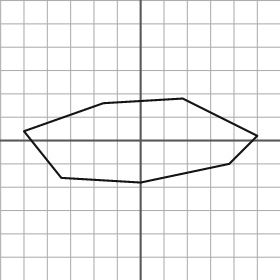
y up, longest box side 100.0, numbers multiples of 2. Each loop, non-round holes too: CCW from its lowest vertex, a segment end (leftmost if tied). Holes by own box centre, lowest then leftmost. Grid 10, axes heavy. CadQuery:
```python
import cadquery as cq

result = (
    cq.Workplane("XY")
    .moveTo(0.0, -18.0)
    .lineTo(38.0, -10.0)
    .lineTo(50.0, 2.0)
    .lineTo(18.0, 18.0)
    .lineTo(-16.0, 16.0)
    .lineTo(-50.0, 4.0)
    .lineTo(-34.0, -16.0)
    .close()
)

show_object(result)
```